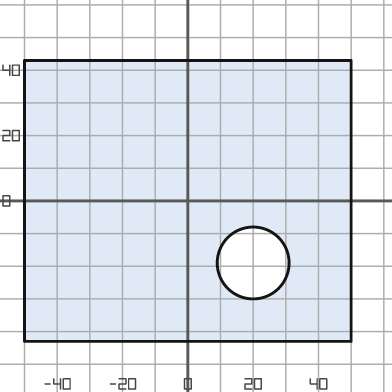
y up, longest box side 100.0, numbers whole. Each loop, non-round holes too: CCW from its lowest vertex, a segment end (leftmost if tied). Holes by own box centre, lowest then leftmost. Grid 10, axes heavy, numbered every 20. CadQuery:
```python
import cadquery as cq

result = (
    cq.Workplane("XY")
    .moveTo(-50.0, -43.0)
    .lineTo(50.0, -43.0)
    .lineTo(50.0, 43.0)
    .lineTo(-50.0, 43.0)
    .close()
    .moveTo(20.0, -19.0)
    .circle(11.0)
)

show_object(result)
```